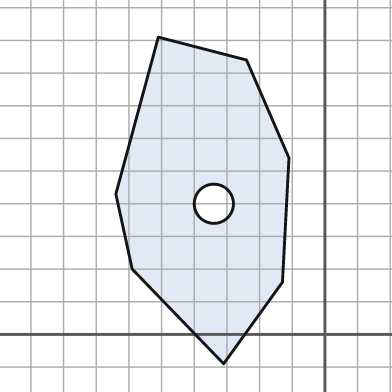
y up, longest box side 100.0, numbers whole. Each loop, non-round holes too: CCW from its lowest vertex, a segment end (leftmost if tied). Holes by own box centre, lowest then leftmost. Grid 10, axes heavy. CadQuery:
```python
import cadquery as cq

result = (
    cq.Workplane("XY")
    .moveTo(-31.0, -9.0)
    .lineTo(-13.0, 16.0)
    .lineTo(-11.0, 54.0)
    .lineTo(-24.0, 84.0)
    .lineTo(-51.0, 91.0)
    .lineTo(-64.0, 43.0)
    .lineTo(-59.0, 20.0)
    .close()
    .moveTo(-34.0, 40.0)
    .circle(6.0)
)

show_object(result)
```